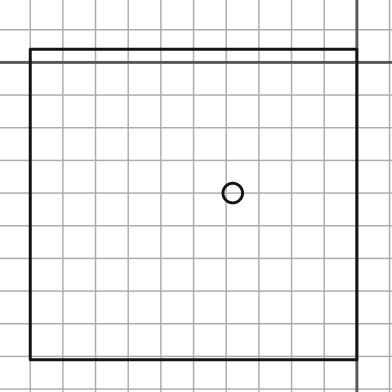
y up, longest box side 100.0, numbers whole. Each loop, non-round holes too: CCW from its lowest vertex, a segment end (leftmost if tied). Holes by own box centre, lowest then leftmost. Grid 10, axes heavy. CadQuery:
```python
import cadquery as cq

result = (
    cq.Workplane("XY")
    .moveTo(-100.0, -91.0)
    .lineTo(0.0, -91.0)
    .lineTo(0.0, 4.0)
    .lineTo(-100.0, 4.0)
    .close()
    .moveTo(-38.0, -40.0)
    .circle(3.0)
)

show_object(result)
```